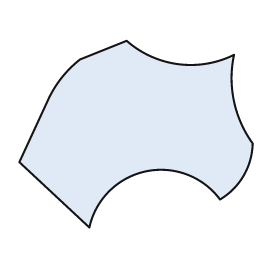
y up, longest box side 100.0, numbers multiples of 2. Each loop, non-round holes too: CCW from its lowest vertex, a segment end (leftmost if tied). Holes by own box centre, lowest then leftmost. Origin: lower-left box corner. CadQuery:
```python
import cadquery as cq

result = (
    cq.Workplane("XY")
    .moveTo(30.0, 0.0)
    .threePointArc((54.0, 24.0), (86.0, 12.0))
    .threePointArc((96.0, 22.0), (100.0, 36.0))
    .threePointArc((92.0, 54.0), (92.0, 74.0))
    .threePointArc((68.0, 70.0), (46.0, 80.0))
    .lineTo(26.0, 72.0)
    .threePointArc((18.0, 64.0), (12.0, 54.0))
    .lineTo(0.0, 28.0)
    .close()
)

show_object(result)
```